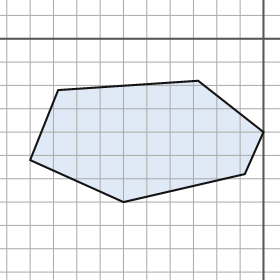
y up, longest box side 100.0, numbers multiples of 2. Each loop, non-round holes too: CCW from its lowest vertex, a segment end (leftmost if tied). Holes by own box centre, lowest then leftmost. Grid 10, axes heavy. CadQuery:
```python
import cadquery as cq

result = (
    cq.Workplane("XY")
    .moveTo(-60.0, -70.0)
    .lineTo(-8.0, -58.0)
    .lineTo(0.0, -40.0)
    .lineTo(-28.0, -18.0)
    .lineTo(-88.0, -22.0)
    .lineTo(-100.0, -52.0)
    .close()
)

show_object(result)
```